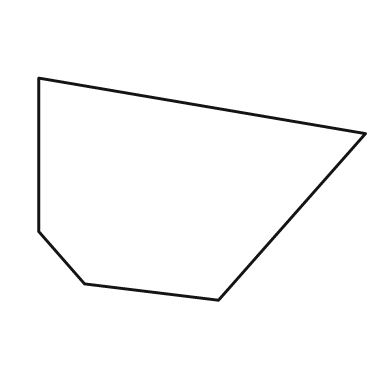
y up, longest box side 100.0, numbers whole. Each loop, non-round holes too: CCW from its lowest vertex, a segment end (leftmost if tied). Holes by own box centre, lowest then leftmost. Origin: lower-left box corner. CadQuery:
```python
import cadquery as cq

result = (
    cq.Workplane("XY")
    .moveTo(55.0, 0.0)
    .lineTo(100.0, 51.0)
    .lineTo(0.0, 68.0)
    .lineTo(0.0, 21.0)
    .lineTo(14.0, 5.0)
    .close()
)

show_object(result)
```